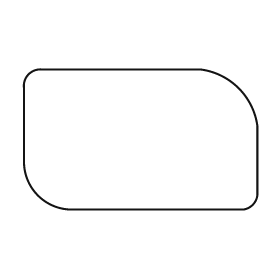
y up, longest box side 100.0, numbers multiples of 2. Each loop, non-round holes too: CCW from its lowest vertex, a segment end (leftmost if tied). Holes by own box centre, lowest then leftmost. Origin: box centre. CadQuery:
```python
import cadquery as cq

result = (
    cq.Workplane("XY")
    .moveTo(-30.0, -30.0)
    .lineTo(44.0, -30.0)
    .threePointArc((48.0, -28.0), (50.0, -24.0))
    .lineTo(50.0, 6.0)
    .threePointArc((42.0, 22.0), (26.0, 30.0))
    .lineTo(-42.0, 30.0)
    .threePointArc((-48.0, 28.0), (-50.0, 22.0))
    .lineTo(-50.0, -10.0)
    .threePointArc((-44.0, -24.0), (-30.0, -30.0))
    .close()
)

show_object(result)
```